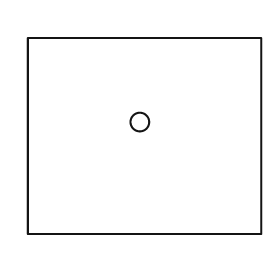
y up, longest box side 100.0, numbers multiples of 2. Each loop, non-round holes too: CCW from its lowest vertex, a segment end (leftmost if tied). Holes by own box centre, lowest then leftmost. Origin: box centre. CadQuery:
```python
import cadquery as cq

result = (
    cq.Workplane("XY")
    .moveTo(-50.0, -42.0)
    .lineTo(50.0, -42.0)
    .lineTo(50.0, 42.0)
    .lineTo(-50.0, 42.0)
    .close()
    .moveTo(-2.0, 6.0)
    .circle(4.0)
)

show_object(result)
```